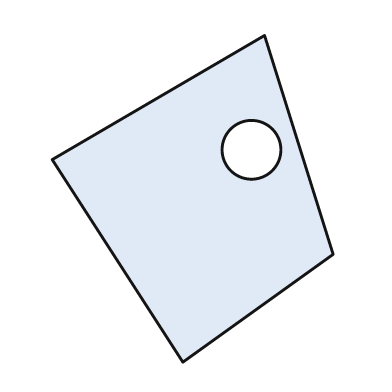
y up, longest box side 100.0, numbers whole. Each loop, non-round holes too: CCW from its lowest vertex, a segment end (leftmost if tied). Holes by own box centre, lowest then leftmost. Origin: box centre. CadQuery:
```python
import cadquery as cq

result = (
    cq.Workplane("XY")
    .moveTo(-3.0, -50.0)
    .lineTo(43.0, -17.0)
    .lineTo(22.0, 50.0)
    .lineTo(-43.0, 12.0)
    .close()
    .moveTo(18.0, 15.0)
    .circle(9.0)
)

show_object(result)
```